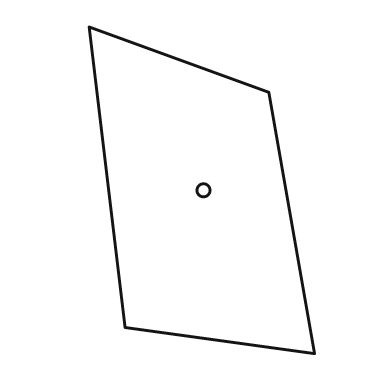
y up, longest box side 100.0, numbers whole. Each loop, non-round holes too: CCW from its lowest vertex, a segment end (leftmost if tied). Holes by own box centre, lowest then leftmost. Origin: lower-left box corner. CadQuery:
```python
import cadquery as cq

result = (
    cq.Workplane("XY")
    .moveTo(69.0, 0.0)
    .lineTo(55.0, 80.0)
    .lineTo(0.0, 100.0)
    .lineTo(11.0, 8.0)
    .close()
    .moveTo(35.0, 50.0)
    .circle(2.0)
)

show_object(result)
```